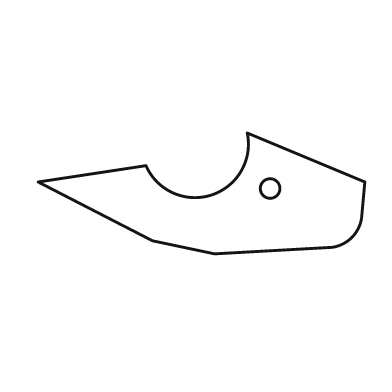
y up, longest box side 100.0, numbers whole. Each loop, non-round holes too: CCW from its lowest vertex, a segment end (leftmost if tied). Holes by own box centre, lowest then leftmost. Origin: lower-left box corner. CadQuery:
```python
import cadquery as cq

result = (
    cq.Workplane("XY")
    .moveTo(54.0, 0.0)
    .lineTo(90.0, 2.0)
    .threePointArc((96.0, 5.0), (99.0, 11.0))
    .lineTo(100.0, 22.0)
    .lineTo(64.0, 37.0)
    .threePointArc((53.0, 18.0), (33.0, 27.0))
    .lineTo(0.0, 22.0)
    .lineTo(35.0, 4.0)
    .close()
    .moveTo(71.0, 20.0)
    .circle(3.0)
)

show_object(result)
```